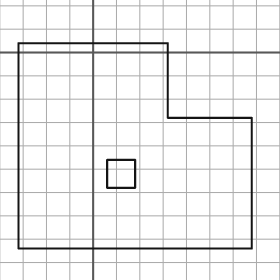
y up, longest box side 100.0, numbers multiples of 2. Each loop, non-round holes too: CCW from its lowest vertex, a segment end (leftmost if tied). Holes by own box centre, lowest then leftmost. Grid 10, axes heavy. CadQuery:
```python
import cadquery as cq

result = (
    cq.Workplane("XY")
    .moveTo(-32.0, -84.0)
    .lineTo(68.0, -84.0)
    .lineTo(68.0, -28.0)
    .lineTo(32.0, -28.0)
    .lineTo(32.0, 4.0)
    .lineTo(-32.0, 4.0)
    .close()
    .moveTo(6.0, -58.0)
    .lineTo(18.0, -58.0)
    .lineTo(18.0, -46.0)
    .lineTo(6.0, -46.0)
    .close()
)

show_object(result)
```